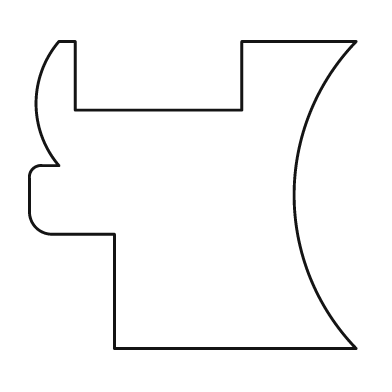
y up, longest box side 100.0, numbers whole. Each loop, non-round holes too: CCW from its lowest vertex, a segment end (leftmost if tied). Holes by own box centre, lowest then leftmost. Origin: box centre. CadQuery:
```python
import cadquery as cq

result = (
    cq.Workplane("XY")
    .moveTo(-24.0, -47.0)
    .lineTo(50.0, -47.0)
    .threePointArc((31.0, 0.0), (50.0, 47.0))
    .lineTo(15.0, 47.0)
    .lineTo(15.0, 26.0)
    .lineTo(-36.0, 26.0)
    .lineTo(-36.0, 47.0)
    .lineTo(-41.0, 47.0)
    .threePointArc((-48.0, 28.0), (-41.0, 9.0))
    .lineTo(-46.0, 9.0)
    .threePointArc((-49.0, 8.0), (-50.0, 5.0))
    .lineTo(-50.0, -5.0)
    .threePointArc((-48.0, -10.0), (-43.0, -12.0))
    .lineTo(-24.0, -12.0)
    .close()
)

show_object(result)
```